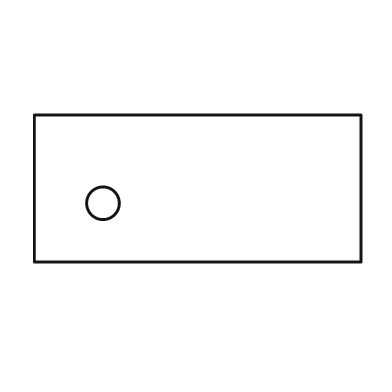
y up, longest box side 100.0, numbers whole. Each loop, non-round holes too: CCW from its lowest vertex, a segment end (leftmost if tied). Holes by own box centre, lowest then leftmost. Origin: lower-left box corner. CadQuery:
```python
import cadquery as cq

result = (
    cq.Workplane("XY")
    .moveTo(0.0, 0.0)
    .lineTo(100.0, 0.0)
    .lineTo(100.0, 45.0)
    .lineTo(0.0, 45.0)
    .close()
    .moveTo(21.0, 18.0)
    .circle(5.0)
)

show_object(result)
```